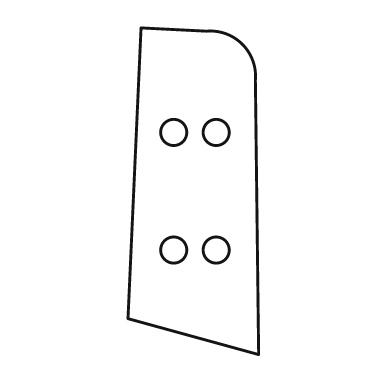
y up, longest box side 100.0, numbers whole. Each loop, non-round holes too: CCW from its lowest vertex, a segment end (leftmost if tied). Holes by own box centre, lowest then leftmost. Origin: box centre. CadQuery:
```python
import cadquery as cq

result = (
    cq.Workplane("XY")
    .moveTo(20.0, -50.0)
    .lineTo(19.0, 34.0)
    .threePointArc((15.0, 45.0), (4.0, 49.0))
    .lineTo(-16.0, 50.0)
    .lineTo(-20.0, -39.0)
    .close()
    .moveTo(-6.0, -18.0)
    .circle(4.0)
    .moveTo(7.0, -18.0)
    .circle(4.0)
    .moveTo(-6.0, 18.0)
    .circle(4.0)
    .moveTo(7.0, 18.0)
    .circle(4.0)
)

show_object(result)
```